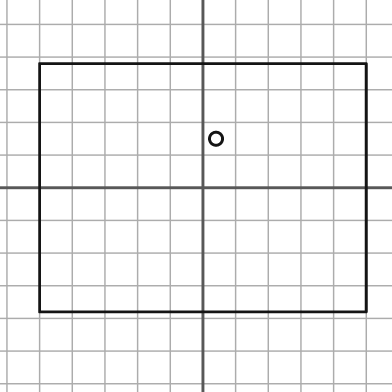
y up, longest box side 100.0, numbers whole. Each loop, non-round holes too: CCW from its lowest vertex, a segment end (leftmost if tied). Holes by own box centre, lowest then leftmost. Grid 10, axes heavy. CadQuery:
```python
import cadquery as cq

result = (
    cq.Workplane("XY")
    .moveTo(-50.0, -38.0)
    .lineTo(50.0, -38.0)
    .lineTo(50.0, 38.0)
    .lineTo(-50.0, 38.0)
    .close()
    .moveTo(4.0, 15.0)
    .circle(2.0)
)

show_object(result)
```